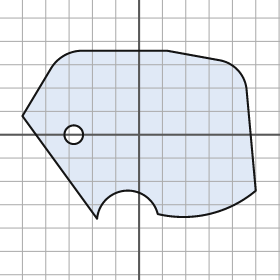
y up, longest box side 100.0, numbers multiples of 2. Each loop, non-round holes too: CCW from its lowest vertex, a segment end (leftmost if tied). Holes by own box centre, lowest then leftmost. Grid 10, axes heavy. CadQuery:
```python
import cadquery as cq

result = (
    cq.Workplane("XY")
    .moveTo(-18.0, -36.0)
    .threePointArc((-6.0, -24.0), (8.0, -34.0))
    .threePointArc((30.0, -34.0), (50.0, -24.0))
    .lineTo(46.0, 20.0)
    .threePointArc((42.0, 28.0), (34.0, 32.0))
    .lineTo(12.0, 36.0)
    .lineTo(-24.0, 36.0)
    .threePointArc((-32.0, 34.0), (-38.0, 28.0))
    .lineTo(-50.0, 8.0)
    .close()
    .moveTo(-28.0, 0.0)
    .circle(4.0)
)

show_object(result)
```